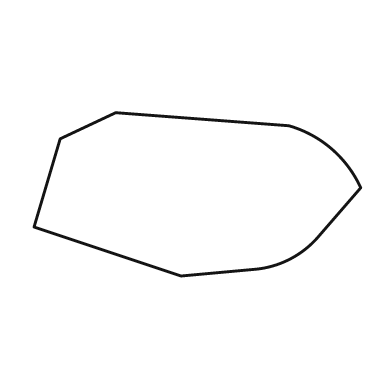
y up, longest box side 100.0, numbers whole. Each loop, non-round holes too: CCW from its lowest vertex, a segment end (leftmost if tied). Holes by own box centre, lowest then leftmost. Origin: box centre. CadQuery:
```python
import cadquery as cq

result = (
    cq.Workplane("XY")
    .moveTo(-5.0, -25.0)
    .lineTo(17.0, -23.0)
    .threePointArc((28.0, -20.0), (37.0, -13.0))
    .lineTo(50.0, 2.0)
    .threePointArc((41.0, 14.0), (28.0, 21.0))
    .lineTo(-25.0, 25.0)
    .lineTo(-42.0, 17.0)
    .lineTo(-50.0, -10.0)
    .close()
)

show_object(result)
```